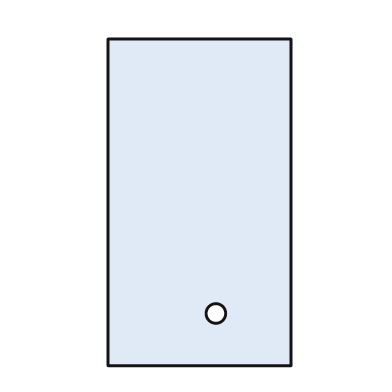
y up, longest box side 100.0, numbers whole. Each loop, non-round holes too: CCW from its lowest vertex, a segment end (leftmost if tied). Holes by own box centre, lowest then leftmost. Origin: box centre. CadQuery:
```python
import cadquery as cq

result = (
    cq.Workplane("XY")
    .moveTo(-28.0, -50.0)
    .lineTo(28.0, -50.0)
    .lineTo(28.0, 50.0)
    .lineTo(-28.0, 50.0)
    .close()
    .moveTo(5.0, -34.0)
    .circle(3.0)
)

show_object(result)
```